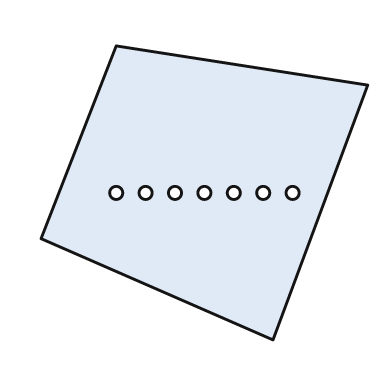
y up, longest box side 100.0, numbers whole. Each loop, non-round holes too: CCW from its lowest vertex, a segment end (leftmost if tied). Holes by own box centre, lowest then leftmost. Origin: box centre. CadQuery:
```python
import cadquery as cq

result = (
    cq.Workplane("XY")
    .moveTo(21.0, -45.0)
    .lineTo(50.0, 33.0)
    .lineTo(-27.0, 45.0)
    .lineTo(-50.0, -14.0)
    .close()
    .moveTo(-27.0, 0.0)
    .circle(2.0)
    .moveTo(-18.0, 0.0)
    .circle(2.0)
    .moveTo(-9.0, 0.0)
    .circle(2.0)
    .moveTo(0.0, 0.0)
    .circle(2.0)
    .moveTo(9.0, 0.0)
    .circle(2.0)
    .moveTo(18.0, 0.0)
    .circle(2.0)
    .moveTo(27.0, 0.0)
    .circle(2.0)
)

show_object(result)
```